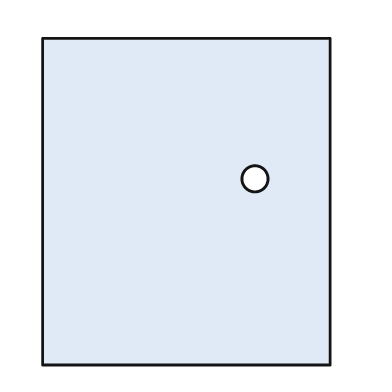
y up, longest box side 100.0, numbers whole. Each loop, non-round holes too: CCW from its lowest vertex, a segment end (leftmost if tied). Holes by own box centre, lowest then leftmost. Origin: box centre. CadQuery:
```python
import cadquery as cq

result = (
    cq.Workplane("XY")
    .moveTo(-44.0, -50.0)
    .lineTo(44.0, -50.0)
    .lineTo(44.0, 50.0)
    .lineTo(-44.0, 50.0)
    .close()
    .moveTo(21.0, 7.0)
    .circle(4.0)
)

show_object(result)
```